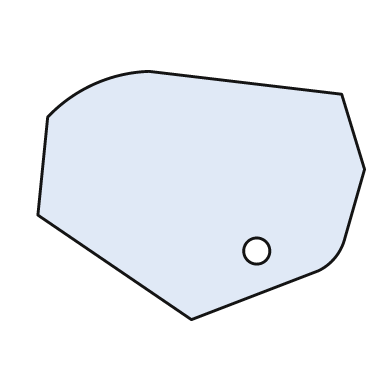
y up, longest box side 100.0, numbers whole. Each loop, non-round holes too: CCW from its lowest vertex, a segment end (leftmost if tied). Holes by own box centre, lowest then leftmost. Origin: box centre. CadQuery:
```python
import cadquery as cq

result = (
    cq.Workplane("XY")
    .moveTo(-3.0, -38.0)
    .lineTo(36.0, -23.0)
    .threePointArc((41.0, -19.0), (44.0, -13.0))
    .lineTo(50.0, 8.0)
    .lineTo(43.0, 31.0)
    .lineTo(-16.0, 38.0)
    .threePointArc((-33.0, 34.0), (-47.0, 24.0))
    .lineTo(-50.0, -6.0)
    .close()
    .moveTo(17.0, -17.0)
    .circle(4.0)
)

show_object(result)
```